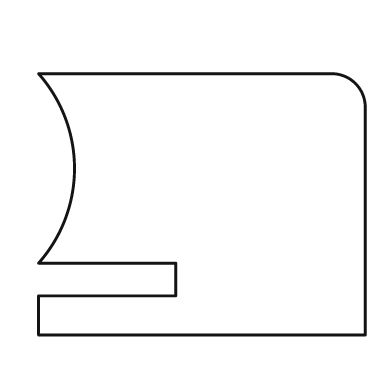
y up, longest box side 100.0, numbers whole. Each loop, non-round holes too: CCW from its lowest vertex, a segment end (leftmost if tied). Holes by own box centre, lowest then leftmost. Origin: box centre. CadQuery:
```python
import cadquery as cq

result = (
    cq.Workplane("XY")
    .moveTo(-50.0, -40.0)
    .lineTo(50.0, -40.0)
    .lineTo(50.0, 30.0)
    .threePointArc((47.0, 37.0), (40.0, 40.0))
    .lineTo(-50.0, 40.0)
    .threePointArc((-39.0, 11.0), (-50.0, -18.0))
    .lineTo(-8.0, -18.0)
    .lineTo(-8.0, -28.0)
    .lineTo(-50.0, -28.0)
    .close()
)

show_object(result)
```